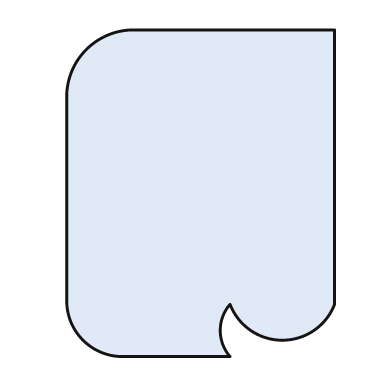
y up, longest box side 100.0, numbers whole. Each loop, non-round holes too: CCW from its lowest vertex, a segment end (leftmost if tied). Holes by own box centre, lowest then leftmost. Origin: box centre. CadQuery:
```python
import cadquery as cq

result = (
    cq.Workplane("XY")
    .moveTo(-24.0, -50.0)
    .lineTo(9.0, -50.0)
    .threePointArc((6.0, -42.0), (9.0, -34.0))
    .threePointArc((25.0, -45.0), (41.0, -34.0))
    .lineTo(41.0, 50.0)
    .lineTo(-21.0, 50.0)
    .threePointArc((-35.0, 44.0), (-41.0, 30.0))
    .lineTo(-41.0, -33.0)
    .threePointArc((-36.0, -45.0), (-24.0, -50.0))
    .close()
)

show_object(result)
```